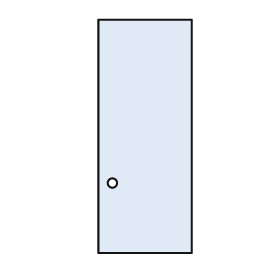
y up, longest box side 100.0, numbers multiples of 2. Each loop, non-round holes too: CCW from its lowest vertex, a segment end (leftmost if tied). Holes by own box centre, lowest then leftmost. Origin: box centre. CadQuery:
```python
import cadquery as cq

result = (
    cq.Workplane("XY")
    .moveTo(-20.0, -50.0)
    .lineTo(20.0, -50.0)
    .lineTo(20.0, 50.0)
    .lineTo(-20.0, 50.0)
    .close()
    .moveTo(-14.0, -20.0)
    .circle(2.0)
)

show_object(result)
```